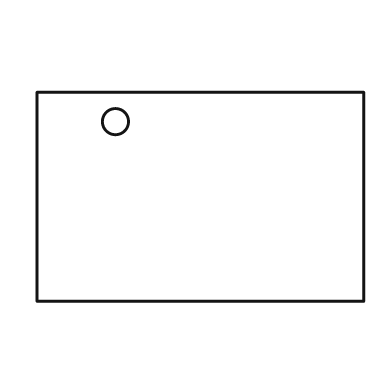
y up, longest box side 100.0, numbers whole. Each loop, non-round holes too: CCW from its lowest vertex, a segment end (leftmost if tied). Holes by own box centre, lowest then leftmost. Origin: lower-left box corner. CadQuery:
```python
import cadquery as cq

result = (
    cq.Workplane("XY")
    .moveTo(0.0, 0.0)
    .lineTo(100.0, 0.0)
    .lineTo(100.0, 64.0)
    .lineTo(0.0, 64.0)
    .close()
    .moveTo(24.0, 55.0)
    .circle(4.0)
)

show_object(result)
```